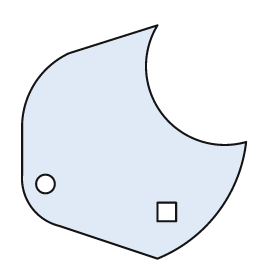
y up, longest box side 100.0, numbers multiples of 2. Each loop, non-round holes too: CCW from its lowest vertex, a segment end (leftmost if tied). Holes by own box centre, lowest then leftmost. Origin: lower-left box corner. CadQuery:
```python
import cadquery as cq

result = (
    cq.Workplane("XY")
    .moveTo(58.0, 0.0)
    .threePointArc((84.0, 20.0), (96.0, 50.0))
    .threePointArc((60.0, 62.0), (58.0, 100.0))
    .lineTo(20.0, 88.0)
    .threePointArc((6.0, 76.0), (0.0, 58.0))
    .lineTo(0.0, 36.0)
    .threePointArc((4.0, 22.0), (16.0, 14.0))
    .close()
    .moveTo(58.0, 16.0)
    .lineTo(66.0, 16.0)
    .lineTo(66.0, 24.0)
    .lineTo(58.0, 24.0)
    .close()
    .moveTo(10.0, 32.0)
    .circle(4.0)
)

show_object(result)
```